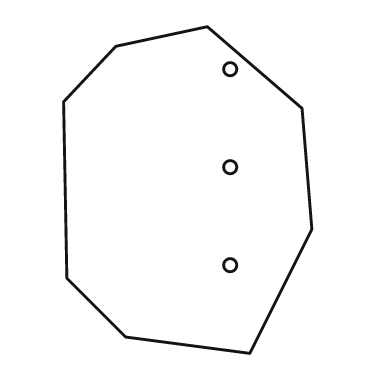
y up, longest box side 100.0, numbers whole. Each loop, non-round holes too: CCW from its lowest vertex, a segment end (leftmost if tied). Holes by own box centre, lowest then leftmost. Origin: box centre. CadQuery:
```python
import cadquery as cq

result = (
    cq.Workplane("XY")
    .moveTo(19.0, -50.0)
    .lineTo(38.0, -12.0)
    .lineTo(35.0, 25.0)
    .lineTo(6.0, 50.0)
    .lineTo(-22.0, 44.0)
    .lineTo(-38.0, 27.0)
    .lineTo(-37.0, -27.0)
    .lineTo(-19.0, -45.0)
    .close()
    .moveTo(13.0, -23.0)
    .circle(2.0)
    .moveTo(13.0, 7.0)
    .circle(2.0)
    .moveTo(13.0, 37.0)
    .circle(2.0)
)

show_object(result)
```